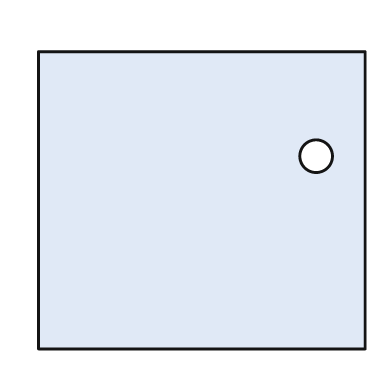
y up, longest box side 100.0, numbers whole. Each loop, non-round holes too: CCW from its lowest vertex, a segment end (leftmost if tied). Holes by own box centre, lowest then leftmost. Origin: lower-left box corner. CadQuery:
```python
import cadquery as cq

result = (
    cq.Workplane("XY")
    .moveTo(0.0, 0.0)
    .lineTo(100.0, 0.0)
    .lineTo(100.0, 91.0)
    .lineTo(0.0, 91.0)
    .close()
    .moveTo(85.0, 59.0)
    .circle(5.0)
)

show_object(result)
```